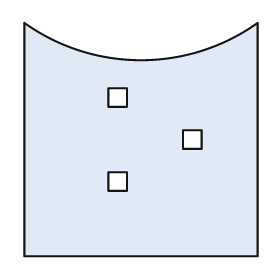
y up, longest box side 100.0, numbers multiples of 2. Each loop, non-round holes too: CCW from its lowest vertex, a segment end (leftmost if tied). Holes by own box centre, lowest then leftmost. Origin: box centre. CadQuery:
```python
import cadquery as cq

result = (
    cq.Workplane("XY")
    .moveTo(-50.0, -50.0)
    .lineTo(50.0, -50.0)
    .lineTo(50.0, 50.0)
    .threePointArc((0.0, 34.0), (-50.0, 50.0))
    .close()
    .moveTo(-14.0, -22.0)
    .lineTo(-6.0, -22.0)
    .lineTo(-6.0, -14.0)
    .lineTo(-14.0, -14.0)
    .close()
    .moveTo(18.0, -4.0)
    .lineTo(26.0, -4.0)
    .lineTo(26.0, 4.0)
    .lineTo(18.0, 4.0)
    .close()
    .moveTo(-14.0, 14.0)
    .lineTo(-6.0, 14.0)
    .lineTo(-6.0, 22.0)
    .lineTo(-14.0, 22.0)
    .close()
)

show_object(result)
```